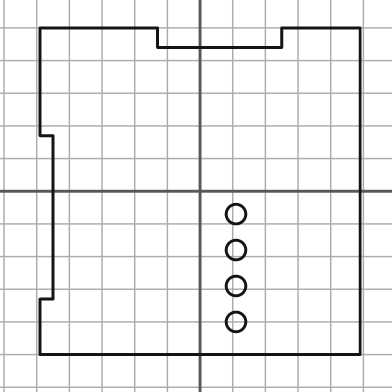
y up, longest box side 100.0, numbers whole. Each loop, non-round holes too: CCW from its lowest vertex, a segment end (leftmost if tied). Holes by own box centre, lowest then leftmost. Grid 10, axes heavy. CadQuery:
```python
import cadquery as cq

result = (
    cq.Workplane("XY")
    .moveTo(-49.0, -50.0)
    .lineTo(49.0, -50.0)
    .lineTo(49.0, 50.0)
    .lineTo(25.0, 50.0)
    .lineTo(25.0, 44.0)
    .lineTo(-13.0, 44.0)
    .lineTo(-13.0, 50.0)
    .lineTo(-49.0, 50.0)
    .lineTo(-49.0, 17.0)
    .lineTo(-45.0, 17.0)
    .lineTo(-45.0, -33.0)
    .lineTo(-49.0, -33.0)
    .close()
    .moveTo(11.0, -40.0)
    .circle(3.0)
    .moveTo(11.0, -29.0)
    .circle(3.0)
    .moveTo(11.0, -18.0)
    .circle(3.0)
    .moveTo(11.0, -7.0)
    .circle(3.0)
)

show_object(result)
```